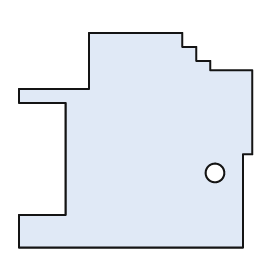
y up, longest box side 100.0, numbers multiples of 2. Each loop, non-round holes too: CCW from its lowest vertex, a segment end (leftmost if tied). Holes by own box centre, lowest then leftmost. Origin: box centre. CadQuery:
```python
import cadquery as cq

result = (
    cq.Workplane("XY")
    .moveTo(-50.0, -46.0)
    .lineTo(46.0, -46.0)
    .lineTo(46.0, -6.0)
    .lineTo(50.0, -6.0)
    .lineTo(50.0, 30.0)
    .lineTo(32.0, 30.0)
    .lineTo(32.0, 34.0)
    .lineTo(26.0, 34.0)
    .lineTo(26.0, 40.0)
    .lineTo(20.0, 40.0)
    .lineTo(20.0, 46.0)
    .lineTo(-20.0, 46.0)
    .lineTo(-20.0, 22.0)
    .lineTo(-50.0, 22.0)
    .lineTo(-50.0, 16.0)
    .lineTo(-30.0, 16.0)
    .lineTo(-30.0, -32.0)
    .lineTo(-50.0, -32.0)
    .close()
    .moveTo(34.0, -14.0)
    .circle(4.0)
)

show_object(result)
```